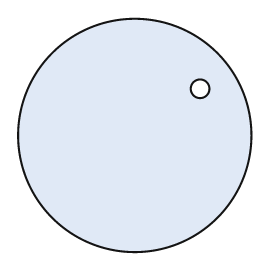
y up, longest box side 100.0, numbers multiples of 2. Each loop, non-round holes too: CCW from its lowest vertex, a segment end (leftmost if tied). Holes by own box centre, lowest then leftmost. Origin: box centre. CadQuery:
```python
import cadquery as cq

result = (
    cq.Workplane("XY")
    .moveTo(0.0, 0.0)
    .circle(50.0)
    .moveTo(28.0, 20.0)
    .circle(4.0)
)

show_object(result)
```